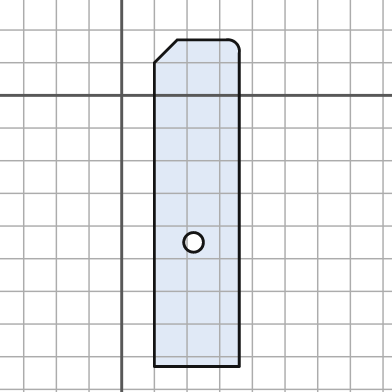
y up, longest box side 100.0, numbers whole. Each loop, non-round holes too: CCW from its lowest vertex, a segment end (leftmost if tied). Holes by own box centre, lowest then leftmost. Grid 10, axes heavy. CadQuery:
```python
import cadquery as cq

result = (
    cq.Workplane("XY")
    .moveTo(10.0, -83.0)
    .lineTo(36.0, -83.0)
    .lineTo(36.0, 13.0)
    .threePointArc((35.0, 16.0), (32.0, 17.0))
    .lineTo(17.0, 17.0)
    .lineTo(10.0, 10.0)
    .close()
    .moveTo(22.0, -45.0)
    .circle(3.0)
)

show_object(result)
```